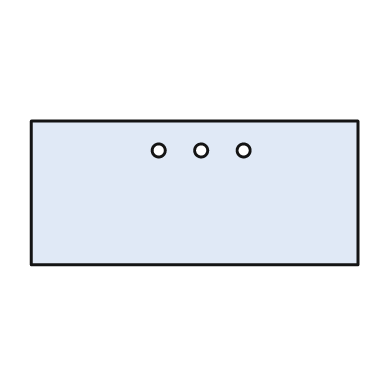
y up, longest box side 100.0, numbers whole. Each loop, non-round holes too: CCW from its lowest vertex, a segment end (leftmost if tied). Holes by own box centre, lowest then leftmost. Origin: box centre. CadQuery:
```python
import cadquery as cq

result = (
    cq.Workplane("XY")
    .moveTo(-50.0, -22.0)
    .lineTo(50.0, -22.0)
    .lineTo(50.0, 22.0)
    .lineTo(-50.0, 22.0)
    .close()
    .moveTo(-11.0, 13.0)
    .circle(2.0)
    .moveTo(2.0, 13.0)
    .circle(2.0)
    .moveTo(15.0, 13.0)
    .circle(2.0)
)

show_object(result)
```